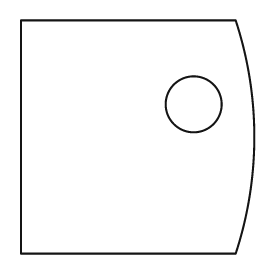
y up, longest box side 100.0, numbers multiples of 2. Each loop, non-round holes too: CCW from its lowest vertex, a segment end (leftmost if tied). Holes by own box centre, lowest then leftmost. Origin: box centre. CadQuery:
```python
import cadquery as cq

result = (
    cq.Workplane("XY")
    .moveTo(-50.0, -50.0)
    .lineTo(42.0, -50.0)
    .threePointArc((50.0, 0.0), (42.0, 50.0))
    .lineTo(-50.0, 50.0)
    .close()
    .moveTo(24.0, 14.0)
    .circle(12.0)
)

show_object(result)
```